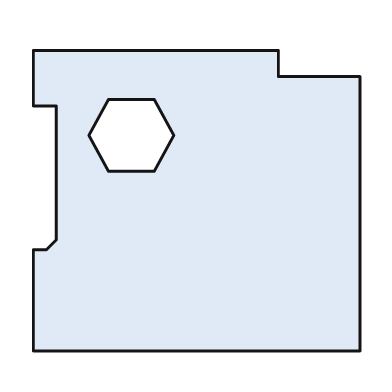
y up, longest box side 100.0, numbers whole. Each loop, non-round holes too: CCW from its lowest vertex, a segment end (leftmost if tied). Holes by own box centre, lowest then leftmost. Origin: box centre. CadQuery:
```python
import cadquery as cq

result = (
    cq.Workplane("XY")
    .moveTo(-50.0, -46.0)
    .lineTo(50.0, -46.0)
    .lineTo(50.0, 38.0)
    .lineTo(25.0, 38.0)
    .lineTo(25.0, 46.0)
    .lineTo(-50.0, 46.0)
    .lineTo(-50.0, 29.0)
    .lineTo(-43.0, 29.0)
    .lineTo(-43.0, -12.0)
    .lineTo(-46.0, -15.0)
    .lineTo(-50.0, -15.0)
    .close()
    .moveTo(-27.0, 9.0)
    .lineTo(-13.0, 9.0)
    .lineTo(-7.0, 20.0)
    .lineTo(-13.0, 31.0)
    .lineTo(-27.0, 31.0)
    .lineTo(-33.0, 20.0)
    .close()
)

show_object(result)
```